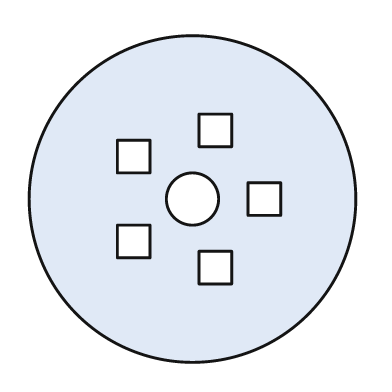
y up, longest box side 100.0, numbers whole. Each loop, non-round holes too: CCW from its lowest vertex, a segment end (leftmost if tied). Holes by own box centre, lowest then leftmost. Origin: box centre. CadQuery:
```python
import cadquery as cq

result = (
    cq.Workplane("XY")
    .moveTo(0.0, 0.0)
    .circle(50.0)
    .moveTo(2.0, -26.0)
    .lineTo(12.0, -26.0)
    .lineTo(12.0, -16.0)
    .lineTo(2.0, -16.0)
    .close()
    .moveTo(-23.0, -18.0)
    .lineTo(-13.0, -18.0)
    .lineTo(-13.0, -8.0)
    .lineTo(-23.0, -8.0)
    .close()
    .moveTo(0.0, 0.0)
    .circle(8.0)
    .moveTo(17.0, -5.0)
    .lineTo(27.0, -5.0)
    .lineTo(27.0, 5.0)
    .lineTo(17.0, 5.0)
    .close()
    .moveTo(-23.0, 8.0)
    .lineTo(-13.0, 8.0)
    .lineTo(-13.0, 18.0)
    .lineTo(-23.0, 18.0)
    .close()
    .moveTo(2.0, 16.0)
    .lineTo(12.0, 16.0)
    .lineTo(12.0, 26.0)
    .lineTo(2.0, 26.0)
    .close()
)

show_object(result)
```